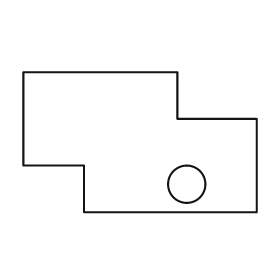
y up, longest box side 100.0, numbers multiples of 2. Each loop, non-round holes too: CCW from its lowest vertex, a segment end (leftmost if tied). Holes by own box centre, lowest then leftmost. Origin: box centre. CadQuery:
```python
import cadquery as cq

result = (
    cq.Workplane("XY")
    .moveTo(-24.0, -30.0)
    .lineTo(50.0, -30.0)
    .lineTo(50.0, 10.0)
    .lineTo(16.0, 10.0)
    .lineTo(16.0, 30.0)
    .lineTo(-50.0, 30.0)
    .lineTo(-50.0, -10.0)
    .lineTo(-24.0, -10.0)
    .close()
    .moveTo(20.0, -18.0)
    .circle(8.0)
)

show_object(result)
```